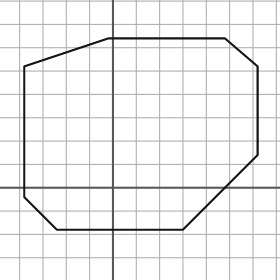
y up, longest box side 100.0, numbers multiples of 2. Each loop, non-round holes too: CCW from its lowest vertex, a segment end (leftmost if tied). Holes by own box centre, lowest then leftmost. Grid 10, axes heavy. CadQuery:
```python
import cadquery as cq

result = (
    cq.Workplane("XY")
    .moveTo(-24.0, -18.0)
    .lineTo(30.0, -18.0)
    .lineTo(62.0, 14.0)
    .lineTo(62.0, 52.0)
    .lineTo(48.0, 64.0)
    .lineTo(-2.0, 64.0)
    .lineTo(-38.0, 52.0)
    .lineTo(-38.0, -4.0)
    .close()
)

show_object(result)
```